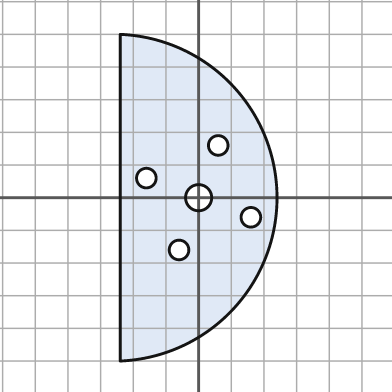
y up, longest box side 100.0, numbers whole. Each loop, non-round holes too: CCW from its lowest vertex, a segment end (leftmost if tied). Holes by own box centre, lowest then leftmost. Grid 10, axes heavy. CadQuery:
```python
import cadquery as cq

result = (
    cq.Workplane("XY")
    .moveTo(-24.0, -50.0)
    .threePointArc((24.0, 0.0), (-24.0, 50.0))
    .close()
    .moveTo(-6.0, -16.0)
    .circle(3.0)
    .moveTo(16.0, -6.0)
    .circle(3.0)
    .moveTo(0.0, 0.0)
    .circle(4.0)
    .moveTo(-16.0, 6.0)
    .circle(3.0)
    .moveTo(6.0, 16.0)
    .circle(3.0)
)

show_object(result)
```